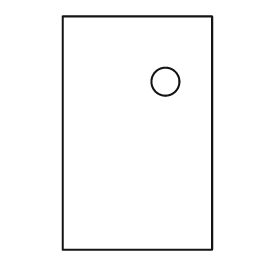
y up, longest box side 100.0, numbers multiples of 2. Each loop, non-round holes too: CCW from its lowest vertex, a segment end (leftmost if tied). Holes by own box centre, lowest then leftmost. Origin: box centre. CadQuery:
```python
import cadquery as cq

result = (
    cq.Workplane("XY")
    .moveTo(-32.0, -50.0)
    .lineTo(32.0, -50.0)
    .lineTo(32.0, 50.0)
    .lineTo(-32.0, 50.0)
    .close()
    .moveTo(12.0, 22.0)
    .circle(6.0)
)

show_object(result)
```